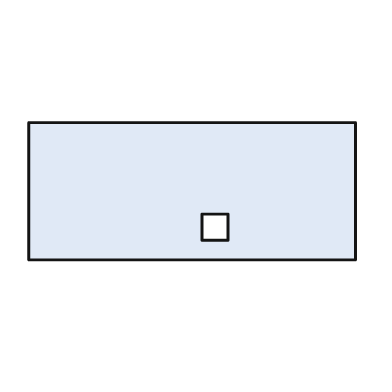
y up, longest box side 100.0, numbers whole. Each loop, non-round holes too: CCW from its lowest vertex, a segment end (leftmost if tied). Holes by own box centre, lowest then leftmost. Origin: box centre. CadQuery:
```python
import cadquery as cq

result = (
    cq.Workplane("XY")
    .moveTo(-50.0, -21.0)
    .lineTo(50.0, -21.0)
    .lineTo(50.0, 21.0)
    .lineTo(-50.0, 21.0)
    .close()
    .moveTo(3.0, -15.0)
    .lineTo(11.0, -15.0)
    .lineTo(11.0, -7.0)
    .lineTo(3.0, -7.0)
    .close()
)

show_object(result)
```